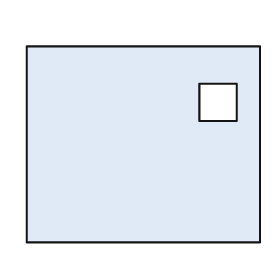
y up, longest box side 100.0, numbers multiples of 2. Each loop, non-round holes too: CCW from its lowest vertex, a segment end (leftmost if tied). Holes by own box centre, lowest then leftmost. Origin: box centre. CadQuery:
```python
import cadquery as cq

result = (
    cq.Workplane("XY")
    .moveTo(-50.0, -42.0)
    .lineTo(50.0, -42.0)
    .lineTo(50.0, 42.0)
    .lineTo(-50.0, 42.0)
    .close()
    .moveTo(24.0, 10.0)
    .lineTo(40.0, 10.0)
    .lineTo(40.0, 26.0)
    .lineTo(24.0, 26.0)
    .close()
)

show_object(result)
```